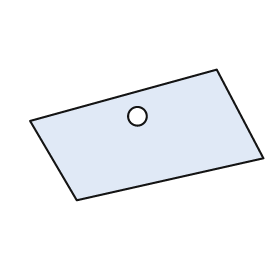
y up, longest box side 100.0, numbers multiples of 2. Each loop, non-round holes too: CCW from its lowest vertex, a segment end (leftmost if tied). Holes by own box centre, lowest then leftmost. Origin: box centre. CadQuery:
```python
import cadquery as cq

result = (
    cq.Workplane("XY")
    .moveTo(-30.0, -28.0)
    .lineTo(50.0, -10.0)
    .lineTo(30.0, 28.0)
    .lineTo(-50.0, 6.0)
    .close()
    .moveTo(-4.0, 8.0)
    .circle(4.0)
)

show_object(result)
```